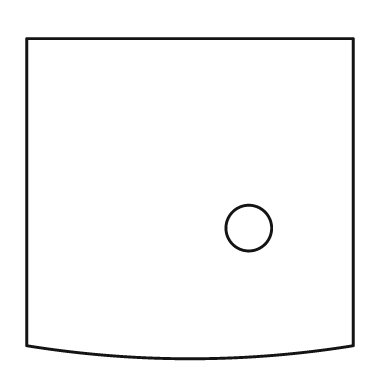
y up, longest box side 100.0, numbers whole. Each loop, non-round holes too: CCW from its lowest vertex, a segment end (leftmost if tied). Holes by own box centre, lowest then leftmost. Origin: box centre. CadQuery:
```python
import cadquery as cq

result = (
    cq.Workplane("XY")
    .moveTo(-50.0, -45.0)
    .threePointArc((0.0, -49.0), (50.0, -45.0))
    .lineTo(50.0, 49.0)
    .lineTo(-50.0, 49.0)
    .close()
    .moveTo(18.0, -9.0)
    .circle(7.0)
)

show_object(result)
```